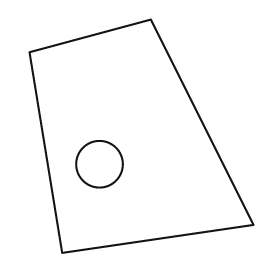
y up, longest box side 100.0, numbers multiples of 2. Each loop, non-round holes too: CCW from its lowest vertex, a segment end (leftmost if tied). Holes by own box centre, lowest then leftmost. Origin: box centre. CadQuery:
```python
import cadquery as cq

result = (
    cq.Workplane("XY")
    .moveTo(-34.0, -50.0)
    .lineTo(48.0, -38.0)
    .lineTo(4.0, 50.0)
    .lineTo(-48.0, 36.0)
    .close()
    .moveTo(-18.0, -12.0)
    .circle(10.0)
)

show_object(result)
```